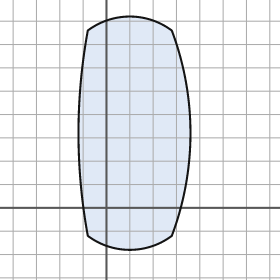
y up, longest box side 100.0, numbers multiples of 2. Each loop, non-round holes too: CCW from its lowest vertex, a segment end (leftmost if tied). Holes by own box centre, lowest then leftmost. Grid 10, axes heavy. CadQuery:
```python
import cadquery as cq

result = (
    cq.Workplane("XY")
    .moveTo(-8.0, -12.0)
    .threePointArc((10.0, -18.0), (28.0, -12.0))
    .threePointArc((36.0, 32.0), (28.0, 76.0))
    .threePointArc((10.0, 82.0), (-8.0, 76.0))
    .threePointArc((-12.0, 32.0), (-8.0, -12.0))
    .close()
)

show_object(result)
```